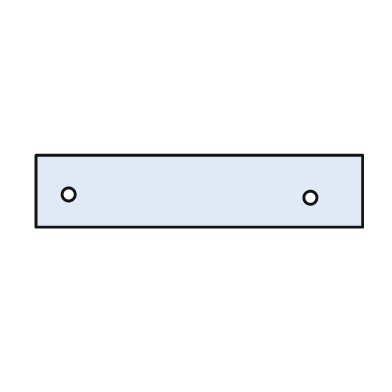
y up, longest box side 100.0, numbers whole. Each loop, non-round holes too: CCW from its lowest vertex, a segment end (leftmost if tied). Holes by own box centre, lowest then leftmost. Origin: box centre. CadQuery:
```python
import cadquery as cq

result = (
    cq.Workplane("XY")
    .moveTo(-50.0, -11.0)
    .lineTo(50.0, -11.0)
    .lineTo(50.0, 11.0)
    .lineTo(-50.0, 11.0)
    .close()
    .moveTo(34.0, -2.0)
    .circle(2.0)
    .moveTo(-40.0, -1.0)
    .circle(2.0)
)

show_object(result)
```